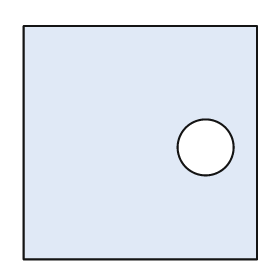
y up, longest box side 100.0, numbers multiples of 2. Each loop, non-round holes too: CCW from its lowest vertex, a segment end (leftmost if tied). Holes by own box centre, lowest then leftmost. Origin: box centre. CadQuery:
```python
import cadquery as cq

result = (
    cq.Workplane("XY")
    .moveTo(-50.0, -50.0)
    .lineTo(50.0, -50.0)
    .lineTo(50.0, 50.0)
    .lineTo(-50.0, 50.0)
    .close()
    .moveTo(28.0, -2.0)
    .circle(12.0)
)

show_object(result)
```